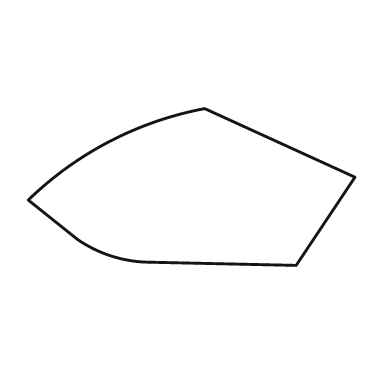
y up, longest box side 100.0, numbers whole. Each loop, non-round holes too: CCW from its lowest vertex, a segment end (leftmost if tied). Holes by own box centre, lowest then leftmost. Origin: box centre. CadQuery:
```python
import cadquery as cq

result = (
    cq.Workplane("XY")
    .moveTo(32.0, -24.0)
    .lineTo(50.0, 3.0)
    .lineTo(4.0, 24.0)
    .threePointArc((-25.0, 14.0), (-50.0, -4.0))
    .lineTo(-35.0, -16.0)
    .threePointArc((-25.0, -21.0), (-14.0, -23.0))
    .close()
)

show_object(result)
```